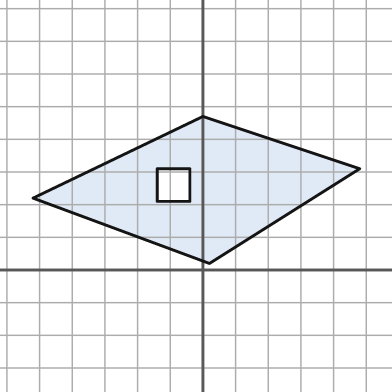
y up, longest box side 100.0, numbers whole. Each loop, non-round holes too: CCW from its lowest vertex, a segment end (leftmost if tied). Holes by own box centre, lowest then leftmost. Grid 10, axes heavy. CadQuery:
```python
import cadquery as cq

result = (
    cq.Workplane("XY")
    .moveTo(2.0, 2.0)
    .lineTo(48.0, 31.0)
    .lineTo(0.0, 47.0)
    .lineTo(-52.0, 22.0)
    .close()
    .moveTo(-14.0, 21.0)
    .lineTo(-4.0, 21.0)
    .lineTo(-4.0, 31.0)
    .lineTo(-14.0, 31.0)
    .close()
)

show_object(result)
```